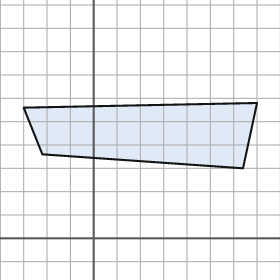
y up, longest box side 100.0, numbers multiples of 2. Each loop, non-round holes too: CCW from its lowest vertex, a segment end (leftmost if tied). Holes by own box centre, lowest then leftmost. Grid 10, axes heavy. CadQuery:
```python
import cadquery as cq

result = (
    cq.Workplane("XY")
    .moveTo(64.0, 30.0)
    .lineTo(70.0, 58.0)
    .lineTo(-30.0, 56.0)
    .lineTo(-22.0, 36.0)
    .close()
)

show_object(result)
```